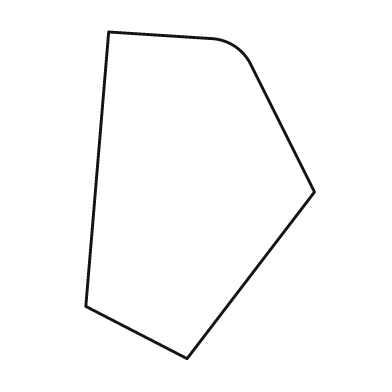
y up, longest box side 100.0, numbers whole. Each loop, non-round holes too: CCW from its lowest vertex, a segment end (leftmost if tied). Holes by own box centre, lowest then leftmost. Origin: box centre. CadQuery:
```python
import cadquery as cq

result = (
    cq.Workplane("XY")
    .moveTo(-4.0, -50.0)
    .lineTo(35.0, 1.0)
    .lineTo(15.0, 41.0)
    .threePointArc((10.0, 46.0), (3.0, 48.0))
    .lineTo(-28.0, 50.0)
    .lineTo(-35.0, -34.0)
    .close()
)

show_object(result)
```